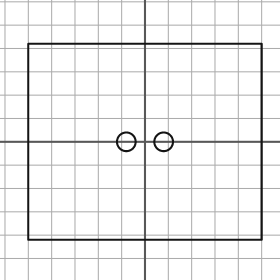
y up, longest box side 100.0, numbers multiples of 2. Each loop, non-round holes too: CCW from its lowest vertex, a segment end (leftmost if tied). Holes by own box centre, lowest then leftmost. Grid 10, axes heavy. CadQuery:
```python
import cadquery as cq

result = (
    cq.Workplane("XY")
    .moveTo(-50.0, -42.0)
    .lineTo(50.0, -42.0)
    .lineTo(50.0, 42.0)
    .lineTo(-50.0, 42.0)
    .close()
    .moveTo(-8.0, 0.0)
    .circle(4.0)
    .moveTo(8.0, 0.0)
    .circle(4.0)
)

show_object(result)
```